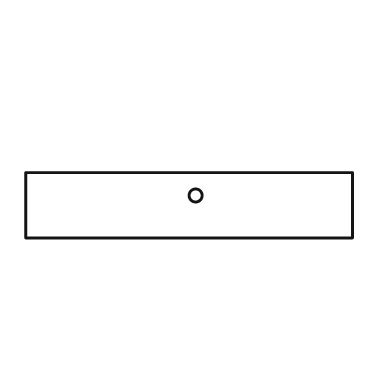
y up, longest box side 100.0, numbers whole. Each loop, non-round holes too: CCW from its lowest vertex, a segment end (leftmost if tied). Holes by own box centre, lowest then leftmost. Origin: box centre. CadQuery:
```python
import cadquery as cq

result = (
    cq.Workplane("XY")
    .moveTo(-50.0, -10.0)
    .lineTo(50.0, -10.0)
    .lineTo(50.0, 10.0)
    .lineTo(-50.0, 10.0)
    .close()
    .moveTo(2.0, 3.0)
    .circle(2.0)
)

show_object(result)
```